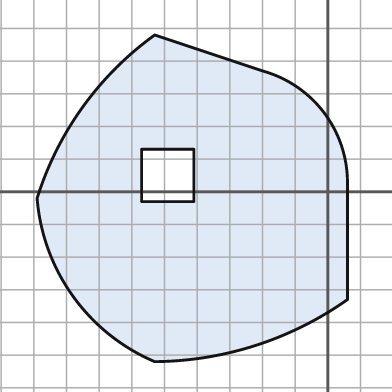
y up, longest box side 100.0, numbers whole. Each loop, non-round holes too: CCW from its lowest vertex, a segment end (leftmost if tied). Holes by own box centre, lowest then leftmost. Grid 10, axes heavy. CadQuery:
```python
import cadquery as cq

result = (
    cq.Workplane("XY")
    .moveTo(-53.0, -52.0)
    .threePointArc((-22.0, -47.0), (6.0, -33.0))
    .lineTo(6.0, 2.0)
    .threePointArc((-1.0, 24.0), (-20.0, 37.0))
    .lineTo(-53.0, 48.0)
    .threePointArc((-75.0, 26.0), (-89.0, -2.0))
    .threePointArc((-78.0, -32.0), (-53.0, -52.0))
    .close()
    .moveTo(-57.0, -3.0)
    .lineTo(-41.0, -3.0)
    .lineTo(-41.0, 13.0)
    .lineTo(-57.0, 13.0)
    .close()
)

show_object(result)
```